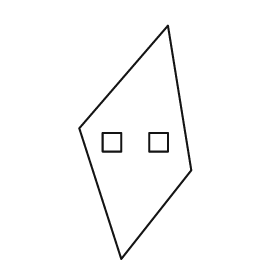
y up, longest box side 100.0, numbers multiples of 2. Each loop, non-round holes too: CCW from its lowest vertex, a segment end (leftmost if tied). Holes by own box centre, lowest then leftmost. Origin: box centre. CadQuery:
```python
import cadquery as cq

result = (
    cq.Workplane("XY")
    .moveTo(-6.0, -50.0)
    .lineTo(24.0, -12.0)
    .lineTo(14.0, 50.0)
    .lineTo(-24.0, 6.0)
    .close()
    .moveTo(-14.0, -4.0)
    .lineTo(-6.0, -4.0)
    .lineTo(-6.0, 4.0)
    .lineTo(-14.0, 4.0)
    .close()
    .moveTo(6.0, -4.0)
    .lineTo(14.0, -4.0)
    .lineTo(14.0, 4.0)
    .lineTo(6.0, 4.0)
    .close()
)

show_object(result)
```